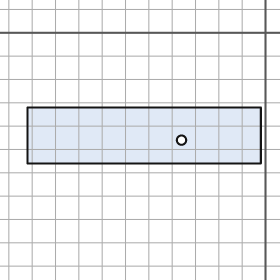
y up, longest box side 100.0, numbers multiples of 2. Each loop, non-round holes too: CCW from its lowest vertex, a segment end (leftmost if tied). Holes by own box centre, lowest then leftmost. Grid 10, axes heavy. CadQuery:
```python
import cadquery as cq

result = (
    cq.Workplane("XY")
    .moveTo(-102.0, -56.0)
    .lineTo(-2.0, -56.0)
    .lineTo(-2.0, -32.0)
    .lineTo(-102.0, -32.0)
    .close()
    .moveTo(-36.0, -46.0)
    .circle(2.0)
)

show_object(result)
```